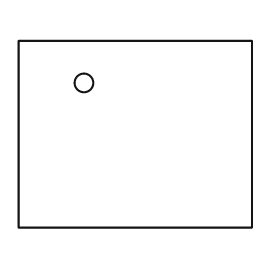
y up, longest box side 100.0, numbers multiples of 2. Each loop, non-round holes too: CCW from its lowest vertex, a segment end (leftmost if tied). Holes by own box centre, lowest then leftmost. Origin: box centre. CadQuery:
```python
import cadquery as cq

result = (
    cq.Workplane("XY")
    .moveTo(-50.0, -40.0)
    .lineTo(50.0, -40.0)
    .lineTo(50.0, 40.0)
    .lineTo(-50.0, 40.0)
    .close()
    .moveTo(-22.0, 22.0)
    .circle(4.0)
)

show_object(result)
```